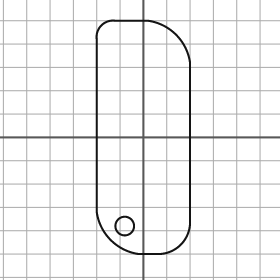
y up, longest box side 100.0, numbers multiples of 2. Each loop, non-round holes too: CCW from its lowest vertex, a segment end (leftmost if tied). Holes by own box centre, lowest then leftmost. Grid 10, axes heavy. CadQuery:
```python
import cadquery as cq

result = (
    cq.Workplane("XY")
    .moveTo(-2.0, -50.0)
    .lineTo(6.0, -50.0)
    .threePointArc((16.0, -46.0), (20.0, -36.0))
    .lineTo(20.0, 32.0)
    .threePointArc((14.0, 44.0), (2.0, 50.0))
    .lineTo(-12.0, 50.0)
    .threePointArc((-18.0, 48.0), (-20.0, 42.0))
    .lineTo(-20.0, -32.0)
    .threePointArc((-14.0, -44.0), (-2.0, -50.0))
    .close()
    .moveTo(-8.0, -38.0)
    .circle(4.0)
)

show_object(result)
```